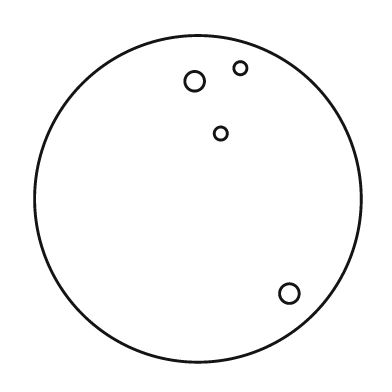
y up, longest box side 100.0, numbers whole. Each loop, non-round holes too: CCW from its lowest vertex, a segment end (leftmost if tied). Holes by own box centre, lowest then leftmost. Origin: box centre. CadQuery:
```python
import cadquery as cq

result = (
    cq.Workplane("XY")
    .moveTo(0.0, 0.0)
    .circle(50.0)
    .moveTo(28.0, -29.0)
    .circle(3.0)
    .moveTo(7.0, 20.0)
    .circle(2.0)
    .moveTo(-1.0, 36.0)
    .circle(3.0)
    .moveTo(13.0, 40.0)
    .circle(2.0)
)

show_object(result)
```